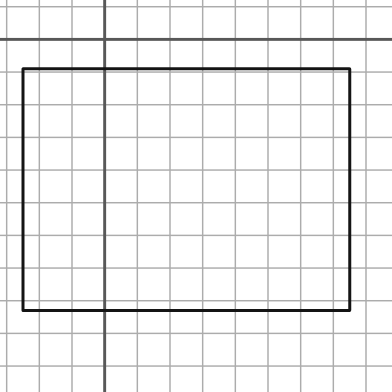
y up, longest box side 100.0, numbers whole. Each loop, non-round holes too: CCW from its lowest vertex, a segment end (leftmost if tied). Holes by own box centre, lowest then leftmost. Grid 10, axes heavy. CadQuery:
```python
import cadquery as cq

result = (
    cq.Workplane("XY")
    .moveTo(-25.0, -83.0)
    .lineTo(75.0, -83.0)
    .lineTo(75.0, -9.0)
    .lineTo(-25.0, -9.0)
    .close()
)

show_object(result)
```